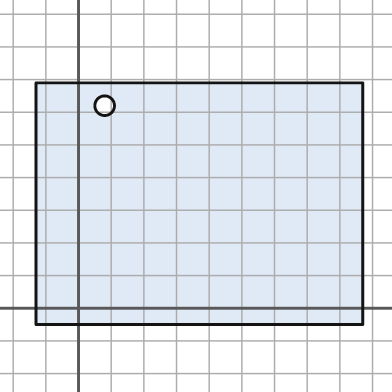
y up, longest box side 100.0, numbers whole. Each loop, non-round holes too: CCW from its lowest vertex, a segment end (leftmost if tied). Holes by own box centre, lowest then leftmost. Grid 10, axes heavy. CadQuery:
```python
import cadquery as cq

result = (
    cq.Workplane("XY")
    .moveTo(-13.0, -5.0)
    .lineTo(87.0, -5.0)
    .lineTo(87.0, 69.0)
    .lineTo(-13.0, 69.0)
    .close()
    .moveTo(8.0, 62.0)
    .circle(3.0)
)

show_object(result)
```